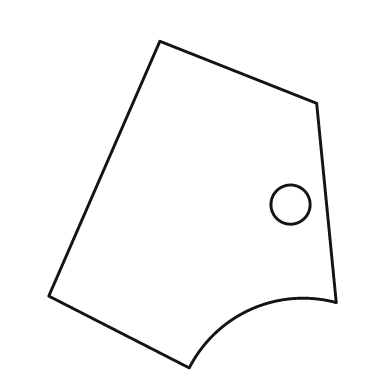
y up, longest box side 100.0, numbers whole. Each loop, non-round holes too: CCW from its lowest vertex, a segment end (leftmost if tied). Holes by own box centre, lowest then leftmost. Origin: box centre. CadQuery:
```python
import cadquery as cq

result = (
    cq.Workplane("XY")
    .moveTo(-1.0, -50.0)
    .threePointArc((18.0, -32.0), (44.0, -30.0))
    .lineTo(38.0, 31.0)
    .lineTo(-10.0, 50.0)
    .lineTo(-44.0, -28.0)
    .close()
    .moveTo(30.0, 0.0)
    .circle(6.0)
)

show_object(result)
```